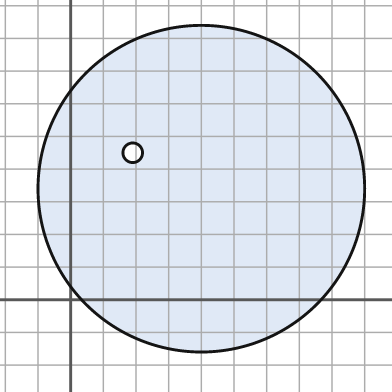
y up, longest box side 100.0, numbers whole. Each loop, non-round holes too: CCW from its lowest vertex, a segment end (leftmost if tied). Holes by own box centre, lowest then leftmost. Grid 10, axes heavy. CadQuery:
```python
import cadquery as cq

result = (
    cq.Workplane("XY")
    .moveTo(40.0, 34.0)
    .circle(50.0)
    .moveTo(19.0, 45.0)
    .circle(3.0)
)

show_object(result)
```